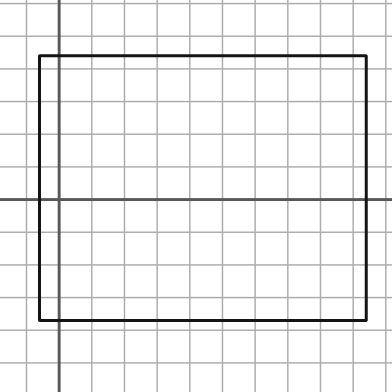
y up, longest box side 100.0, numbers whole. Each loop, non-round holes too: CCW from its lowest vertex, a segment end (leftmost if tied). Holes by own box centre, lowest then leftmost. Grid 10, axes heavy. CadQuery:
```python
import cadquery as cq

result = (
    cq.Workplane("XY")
    .moveTo(-6.0, -37.0)
    .lineTo(94.0, -37.0)
    .lineTo(94.0, 44.0)
    .lineTo(-6.0, 44.0)
    .close()
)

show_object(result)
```